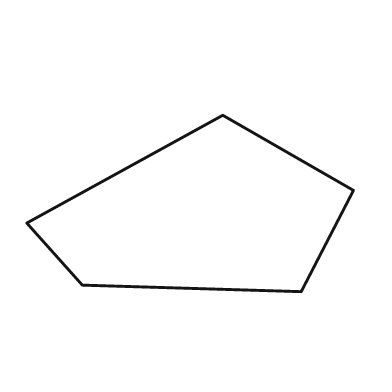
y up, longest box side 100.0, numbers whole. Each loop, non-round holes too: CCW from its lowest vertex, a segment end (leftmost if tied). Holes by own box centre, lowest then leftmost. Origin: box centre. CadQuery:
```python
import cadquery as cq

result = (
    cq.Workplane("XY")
    .moveTo(34.0, -27.0)
    .lineTo(50.0, 4.0)
    .lineTo(10.0, 27.0)
    .lineTo(-50.0, -6.0)
    .lineTo(-33.0, -25.0)
    .close()
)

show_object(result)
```